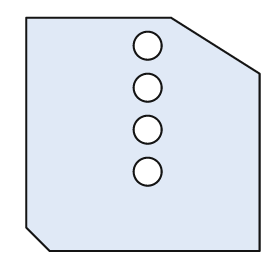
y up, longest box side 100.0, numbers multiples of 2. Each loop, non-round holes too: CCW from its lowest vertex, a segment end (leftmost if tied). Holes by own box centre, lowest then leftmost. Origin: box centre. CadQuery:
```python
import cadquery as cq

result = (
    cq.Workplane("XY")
    .moveTo(-40.0, -50.0)
    .lineTo(50.0, -50.0)
    .lineTo(50.0, 26.0)
    .lineTo(12.0, 50.0)
    .lineTo(-50.0, 50.0)
    .lineTo(-50.0, -40.0)
    .close()
    .moveTo(2.0, -16.0)
    .circle(6.0)
    .moveTo(2.0, 2.0)
    .circle(6.0)
    .moveTo(2.0, 20.0)
    .circle(6.0)
    .moveTo(2.0, 38.0)
    .circle(6.0)
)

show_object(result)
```